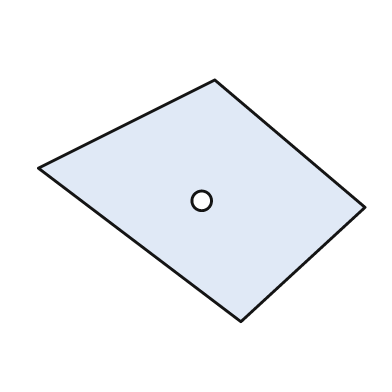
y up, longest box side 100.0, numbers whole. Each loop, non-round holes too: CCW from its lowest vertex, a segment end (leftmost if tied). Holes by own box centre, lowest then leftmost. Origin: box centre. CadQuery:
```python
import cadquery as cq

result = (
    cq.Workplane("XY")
    .moveTo(12.0, -37.0)
    .lineTo(50.0, -2.0)
    .lineTo(4.0, 37.0)
    .lineTo(-50.0, 10.0)
    .close()
    .moveTo(0.0, 0.0)
    .circle(3.0)
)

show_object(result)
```